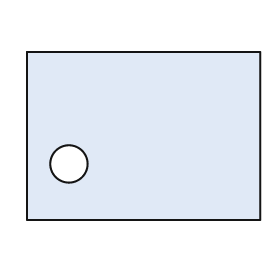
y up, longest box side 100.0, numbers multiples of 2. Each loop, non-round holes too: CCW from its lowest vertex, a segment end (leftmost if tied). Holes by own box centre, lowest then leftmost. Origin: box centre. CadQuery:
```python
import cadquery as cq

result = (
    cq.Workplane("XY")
    .moveTo(-50.0, -36.0)
    .lineTo(50.0, -36.0)
    .lineTo(50.0, 36.0)
    .lineTo(-50.0, 36.0)
    .close()
    .moveTo(-32.0, -12.0)
    .circle(8.0)
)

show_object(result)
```